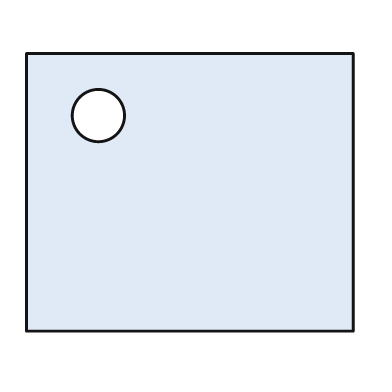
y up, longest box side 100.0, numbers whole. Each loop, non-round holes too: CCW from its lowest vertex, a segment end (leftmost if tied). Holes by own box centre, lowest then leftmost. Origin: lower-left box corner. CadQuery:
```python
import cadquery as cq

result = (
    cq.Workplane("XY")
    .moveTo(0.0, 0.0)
    .lineTo(100.0, 0.0)
    .lineTo(100.0, 85.0)
    .lineTo(0.0, 85.0)
    .close()
    .moveTo(22.0, 66.0)
    .circle(8.0)
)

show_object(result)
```